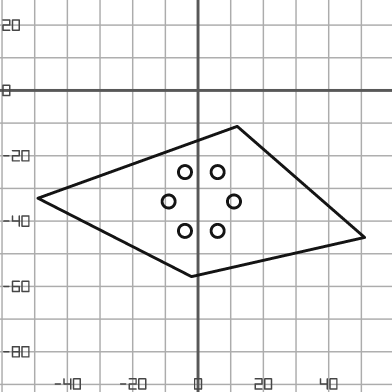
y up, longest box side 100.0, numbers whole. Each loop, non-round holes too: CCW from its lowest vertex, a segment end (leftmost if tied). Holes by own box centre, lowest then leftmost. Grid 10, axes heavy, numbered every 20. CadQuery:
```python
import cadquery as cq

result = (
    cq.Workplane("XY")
    .moveTo(-2.0, -57.0)
    .lineTo(51.0, -45.0)
    .lineTo(12.0, -11.0)
    .lineTo(-49.0, -33.0)
    .close()
    .moveTo(-4.0, -43.0)
    .circle(2.0)
    .moveTo(6.0, -43.0)
    .circle(2.0)
    .moveTo(-9.0, -34.0)
    .circle(2.0)
    .moveTo(11.0, -34.0)
    .circle(2.0)
    .moveTo(-4.0, -25.0)
    .circle(2.0)
    .moveTo(6.0, -25.0)
    .circle(2.0)
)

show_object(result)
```